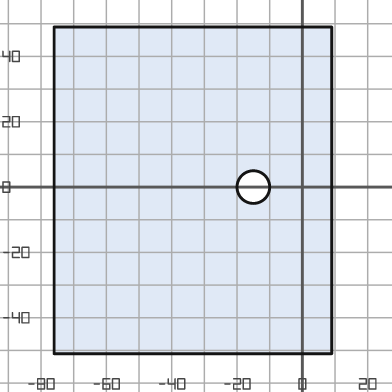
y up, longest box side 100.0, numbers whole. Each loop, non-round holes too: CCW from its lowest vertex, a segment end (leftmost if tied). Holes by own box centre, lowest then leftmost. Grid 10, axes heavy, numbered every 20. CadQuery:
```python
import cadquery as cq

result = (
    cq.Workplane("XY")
    .moveTo(-76.0, -51.0)
    .lineTo(9.0, -51.0)
    .lineTo(9.0, 49.0)
    .lineTo(-76.0, 49.0)
    .close()
    .moveTo(-15.0, 0.0)
    .circle(5.0)
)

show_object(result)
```